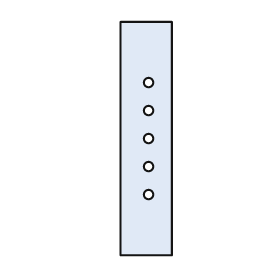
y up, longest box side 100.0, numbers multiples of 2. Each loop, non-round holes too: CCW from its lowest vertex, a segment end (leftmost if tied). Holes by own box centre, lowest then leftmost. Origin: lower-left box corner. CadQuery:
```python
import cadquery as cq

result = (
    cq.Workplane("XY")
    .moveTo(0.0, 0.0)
    .lineTo(22.0, 0.0)
    .lineTo(22.0, 100.0)
    .lineTo(0.0, 100.0)
    .close()
    .moveTo(12.0, 26.0)
    .circle(2.0)
    .moveTo(12.0, 38.0)
    .circle(2.0)
    .moveTo(12.0, 50.0)
    .circle(2.0)
    .moveTo(12.0, 62.0)
    .circle(2.0)
    .moveTo(12.0, 74.0)
    .circle(2.0)
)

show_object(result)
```